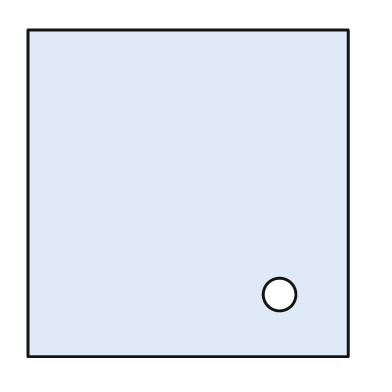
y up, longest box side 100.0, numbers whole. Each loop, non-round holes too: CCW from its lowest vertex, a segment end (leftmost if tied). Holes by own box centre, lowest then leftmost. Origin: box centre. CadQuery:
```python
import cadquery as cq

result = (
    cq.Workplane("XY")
    .moveTo(-49.0, -50.0)
    .lineTo(49.0, -50.0)
    .lineTo(49.0, 50.0)
    .lineTo(-49.0, 50.0)
    .close()
    .moveTo(28.0, -31.0)
    .circle(5.0)
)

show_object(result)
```